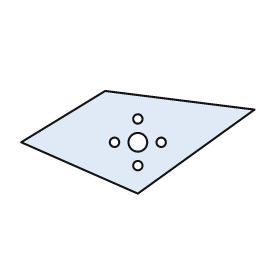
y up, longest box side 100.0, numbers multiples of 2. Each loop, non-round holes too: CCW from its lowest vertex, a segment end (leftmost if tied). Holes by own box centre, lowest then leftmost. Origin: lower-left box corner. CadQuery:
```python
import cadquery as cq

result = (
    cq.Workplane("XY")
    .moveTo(50.0, 0.0)
    .lineTo(100.0, 36.0)
    .lineTo(36.0, 44.0)
    .lineTo(0.0, 22.0)
    .close()
    .moveTo(50.0, 12.0)
    .circle(2.0)
    .moveTo(40.0, 22.0)
    .circle(2.0)
    .moveTo(50.0, 22.0)
    .circle(4.0)
    .moveTo(60.0, 22.0)
    .circle(2.0)
    .moveTo(50.0, 32.0)
    .circle(2.0)
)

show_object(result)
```